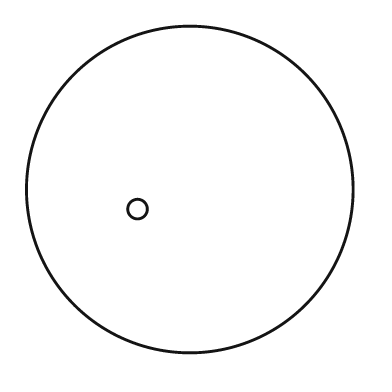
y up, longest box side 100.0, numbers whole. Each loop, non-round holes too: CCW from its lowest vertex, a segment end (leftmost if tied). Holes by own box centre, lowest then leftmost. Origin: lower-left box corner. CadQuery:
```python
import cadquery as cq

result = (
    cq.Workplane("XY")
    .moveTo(50.0, 50.0)
    .circle(50.0)
    .moveTo(34.0, 44.0)
    .circle(3.0)
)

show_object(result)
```